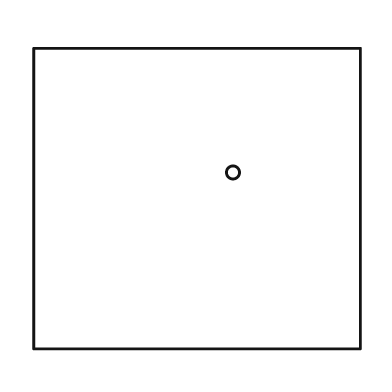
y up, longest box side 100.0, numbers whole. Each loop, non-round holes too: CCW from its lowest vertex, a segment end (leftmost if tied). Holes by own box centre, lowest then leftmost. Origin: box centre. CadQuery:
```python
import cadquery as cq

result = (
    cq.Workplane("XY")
    .moveTo(-50.0, -46.0)
    .lineTo(50.0, -46.0)
    .lineTo(50.0, 46.0)
    .lineTo(-50.0, 46.0)
    .close()
    .moveTo(11.0, 8.0)
    .circle(2.0)
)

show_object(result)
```